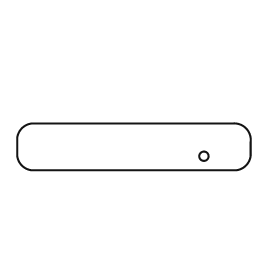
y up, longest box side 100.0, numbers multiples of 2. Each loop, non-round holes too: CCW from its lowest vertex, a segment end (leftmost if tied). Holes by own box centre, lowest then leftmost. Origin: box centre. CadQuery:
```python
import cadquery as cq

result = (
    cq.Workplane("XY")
    .moveTo(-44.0, -10.0)
    .lineTo(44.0, -10.0)
    .threePointArc((48.0, -8.0), (50.0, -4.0))
    .lineTo(50.0, 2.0)
    .threePointArc((48.0, 8.0), (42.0, 10.0))
    .lineTo(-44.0, 10.0)
    .threePointArc((-48.0, 8.0), (-50.0, 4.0))
    .lineTo(-50.0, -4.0)
    .threePointArc((-48.0, -8.0), (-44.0, -10.0))
    .close()
    .moveTo(30.0, -4.0)
    .circle(2.0)
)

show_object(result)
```